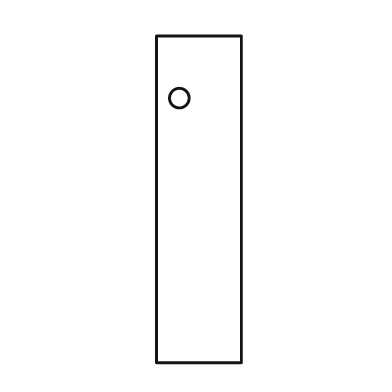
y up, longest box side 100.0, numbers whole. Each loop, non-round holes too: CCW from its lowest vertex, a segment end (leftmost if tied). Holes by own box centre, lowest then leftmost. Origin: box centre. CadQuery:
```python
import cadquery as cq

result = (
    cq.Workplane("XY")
    .moveTo(-13.0, -50.0)
    .lineTo(13.0, -50.0)
    .lineTo(13.0, 50.0)
    .lineTo(-13.0, 50.0)
    .close()
    .moveTo(-6.0, 31.0)
    .circle(3.0)
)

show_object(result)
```